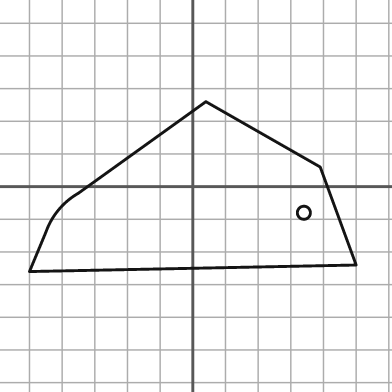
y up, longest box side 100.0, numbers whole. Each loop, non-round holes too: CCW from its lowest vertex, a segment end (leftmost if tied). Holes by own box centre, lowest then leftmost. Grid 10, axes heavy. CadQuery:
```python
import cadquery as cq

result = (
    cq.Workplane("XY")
    .moveTo(-50.0, -26.0)
    .lineTo(50.0, -24.0)
    .lineTo(39.0, 6.0)
    .lineTo(4.0, 26.0)
    .lineTo(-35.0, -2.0)
    .threePointArc((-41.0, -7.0), (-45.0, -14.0))
    .close()
    .moveTo(34.0, -8.0)
    .circle(2.0)
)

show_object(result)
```